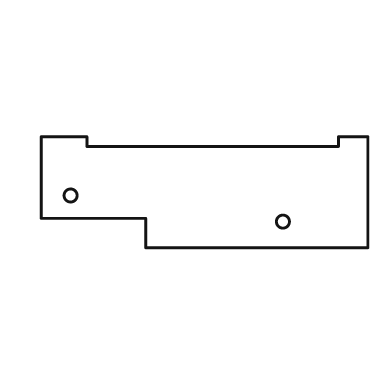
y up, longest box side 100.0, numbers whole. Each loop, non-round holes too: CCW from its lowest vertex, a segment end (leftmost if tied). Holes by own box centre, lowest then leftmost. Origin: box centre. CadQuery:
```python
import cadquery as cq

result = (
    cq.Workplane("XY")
    .moveTo(-18.0, -17.0)
    .lineTo(50.0, -17.0)
    .lineTo(50.0, 17.0)
    .lineTo(41.0, 17.0)
    .lineTo(41.0, 14.0)
    .lineTo(-36.0, 14.0)
    .lineTo(-36.0, 17.0)
    .lineTo(-50.0, 17.0)
    .lineTo(-50.0, -8.0)
    .lineTo(-18.0, -8.0)
    .close()
    .moveTo(24.0, -9.0)
    .circle(2.0)
    .moveTo(-41.0, -1.0)
    .circle(2.0)
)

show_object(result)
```